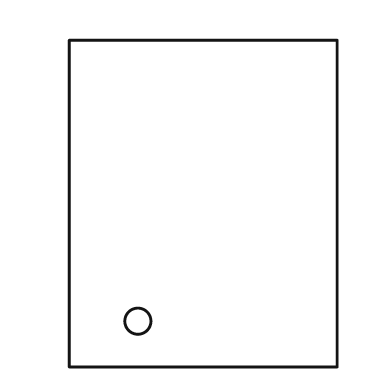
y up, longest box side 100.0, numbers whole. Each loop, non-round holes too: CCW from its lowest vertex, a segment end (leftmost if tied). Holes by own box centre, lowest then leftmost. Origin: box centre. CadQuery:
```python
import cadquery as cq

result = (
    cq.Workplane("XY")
    .moveTo(-41.0, -50.0)
    .lineTo(41.0, -50.0)
    .lineTo(41.0, 50.0)
    .lineTo(-41.0, 50.0)
    .close()
    .moveTo(-20.0, -36.0)
    .circle(4.0)
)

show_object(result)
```